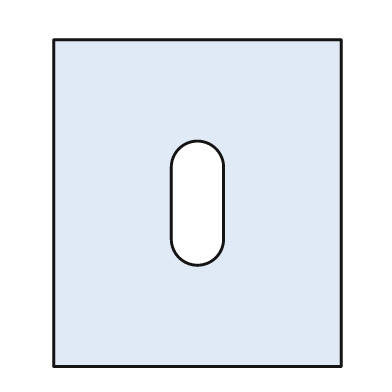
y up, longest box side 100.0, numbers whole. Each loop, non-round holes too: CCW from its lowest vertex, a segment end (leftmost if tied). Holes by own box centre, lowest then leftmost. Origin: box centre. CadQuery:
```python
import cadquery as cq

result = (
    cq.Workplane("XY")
    .moveTo(-44.0, -50.0)
    .lineTo(44.0, -50.0)
    .lineTo(44.0, 50.0)
    .lineTo(-44.0, 50.0)
    .close()
    .moveTo(-8.0, -11.0)
    .threePointArc((0.0, -19.0), (8.0, -11.0))
    .lineTo(8.0, 11.0)
    .threePointArc((0.0, 19.0), (-8.0, 11.0))
    .close()
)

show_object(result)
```